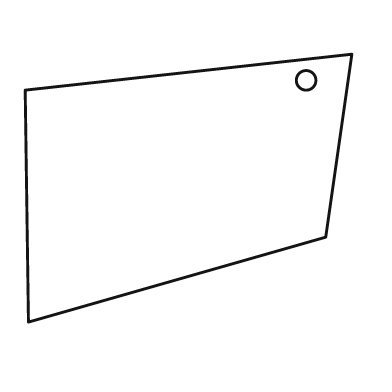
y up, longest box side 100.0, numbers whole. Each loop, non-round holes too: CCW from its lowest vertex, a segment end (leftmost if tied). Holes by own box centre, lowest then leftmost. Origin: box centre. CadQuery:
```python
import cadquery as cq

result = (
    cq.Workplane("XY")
    .moveTo(-49.0, -41.0)
    .lineTo(42.0, -15.0)
    .lineTo(50.0, 41.0)
    .lineTo(-50.0, 30.0)
    .close()
    .moveTo(36.0, 33.0)
    .circle(3.0)
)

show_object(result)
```